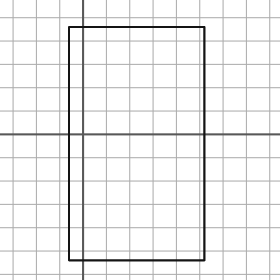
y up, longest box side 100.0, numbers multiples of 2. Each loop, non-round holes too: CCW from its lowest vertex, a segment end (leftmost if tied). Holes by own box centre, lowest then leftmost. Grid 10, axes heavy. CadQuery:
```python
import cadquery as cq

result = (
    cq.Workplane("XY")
    .moveTo(-6.0, -54.0)
    .lineTo(52.0, -54.0)
    .lineTo(52.0, 46.0)
    .lineTo(-6.0, 46.0)
    .close()
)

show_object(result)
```